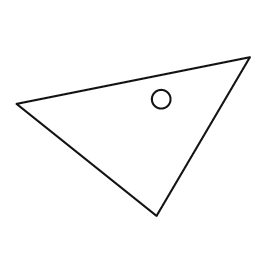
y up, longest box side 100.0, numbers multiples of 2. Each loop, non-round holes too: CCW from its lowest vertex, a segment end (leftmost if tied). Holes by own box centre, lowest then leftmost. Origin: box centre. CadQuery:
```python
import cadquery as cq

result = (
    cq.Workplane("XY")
    .moveTo(10.0, -34.0)
    .lineTo(50.0, 34.0)
    .lineTo(-50.0, 14.0)
    .close()
    .moveTo(12.0, 16.0)
    .circle(4.0)
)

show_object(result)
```